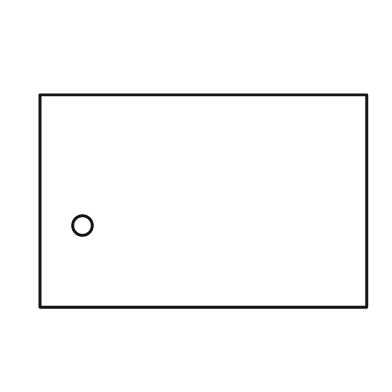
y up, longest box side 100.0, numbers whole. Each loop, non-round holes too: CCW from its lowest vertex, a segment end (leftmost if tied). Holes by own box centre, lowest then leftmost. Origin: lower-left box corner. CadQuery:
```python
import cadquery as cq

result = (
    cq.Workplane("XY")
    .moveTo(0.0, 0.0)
    .lineTo(100.0, 0.0)
    .lineTo(100.0, 65.0)
    .lineTo(0.0, 65.0)
    .close()
    .moveTo(13.0, 25.0)
    .circle(3.0)
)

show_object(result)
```